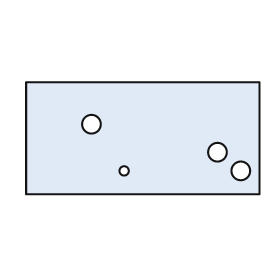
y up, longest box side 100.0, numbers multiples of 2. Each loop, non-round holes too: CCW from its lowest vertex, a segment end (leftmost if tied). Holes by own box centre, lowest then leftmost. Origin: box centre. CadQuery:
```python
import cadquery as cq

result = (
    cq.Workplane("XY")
    .moveTo(-50.0, -24.0)
    .lineTo(50.0, -24.0)
    .lineTo(50.0, 24.0)
    .lineTo(-50.0, 24.0)
    .close()
    .moveTo(-8.0, -14.0)
    .circle(2.0)
    .moveTo(42.0, -14.0)
    .circle(4.0)
    .moveTo(32.0, -6.0)
    .circle(4.0)
    .moveTo(-22.0, 6.0)
    .circle(4.0)
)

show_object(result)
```